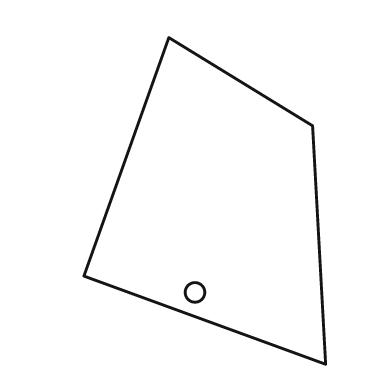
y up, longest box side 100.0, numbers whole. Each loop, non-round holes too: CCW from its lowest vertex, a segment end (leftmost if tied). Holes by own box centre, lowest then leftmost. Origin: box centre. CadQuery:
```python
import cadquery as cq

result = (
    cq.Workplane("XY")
    .moveTo(37.0, -50.0)
    .lineTo(33.0, 23.0)
    .lineTo(-11.0, 50.0)
    .lineTo(-37.0, -23.0)
    .close()
    .moveTo(-3.0, -28.0)
    .circle(3.0)
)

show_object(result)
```